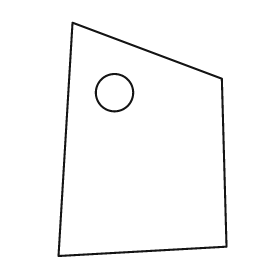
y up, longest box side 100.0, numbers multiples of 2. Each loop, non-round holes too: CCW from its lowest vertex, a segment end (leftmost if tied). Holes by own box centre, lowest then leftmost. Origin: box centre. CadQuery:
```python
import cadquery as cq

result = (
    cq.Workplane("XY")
    .moveTo(-36.0, -50.0)
    .lineTo(36.0, -46.0)
    .lineTo(34.0, 26.0)
    .lineTo(-30.0, 50.0)
    .close()
    .moveTo(-12.0, 20.0)
    .circle(8.0)
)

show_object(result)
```